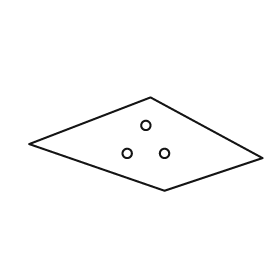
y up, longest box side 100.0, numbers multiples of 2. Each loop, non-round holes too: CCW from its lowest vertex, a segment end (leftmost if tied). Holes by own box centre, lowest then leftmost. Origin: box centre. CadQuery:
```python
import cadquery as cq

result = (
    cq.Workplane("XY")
    .moveTo(8.0, -20.0)
    .lineTo(50.0, -6.0)
    .lineTo(2.0, 20.0)
    .lineTo(-50.0, 0.0)
    .close()
    .moveTo(-8.0, -4.0)
    .circle(2.0)
    .moveTo(8.0, -4.0)
    .circle(2.0)
    .moveTo(0.0, 8.0)
    .circle(2.0)
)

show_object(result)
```